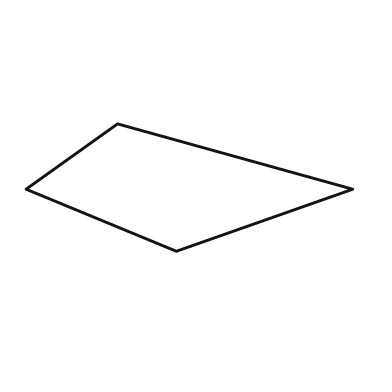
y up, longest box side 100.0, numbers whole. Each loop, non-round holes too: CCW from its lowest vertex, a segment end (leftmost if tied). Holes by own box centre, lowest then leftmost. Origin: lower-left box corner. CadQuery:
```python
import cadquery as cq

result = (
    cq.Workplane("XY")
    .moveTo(46.0, 0.0)
    .lineTo(100.0, 19.0)
    .lineTo(28.0, 39.0)
    .lineTo(0.0, 19.0)
    .close()
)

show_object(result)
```